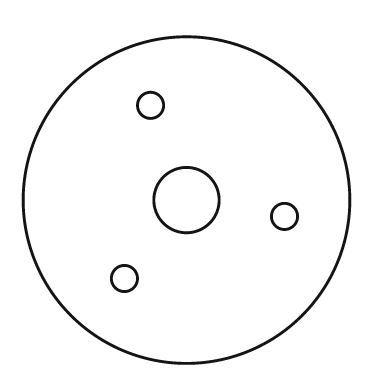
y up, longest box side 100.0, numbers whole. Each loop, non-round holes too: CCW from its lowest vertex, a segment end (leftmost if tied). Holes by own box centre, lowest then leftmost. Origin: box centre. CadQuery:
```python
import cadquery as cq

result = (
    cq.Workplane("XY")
    .moveTo(0.0, 0.0)
    .circle(50.0)
    .moveTo(-19.0, -24.0)
    .circle(4.0)
    .moveTo(30.0, -5.0)
    .circle(4.0)
    .moveTo(0.0, 0.0)
    .circle(10.0)
    .moveTo(-11.0, 29.0)
    .circle(4.0)
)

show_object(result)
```